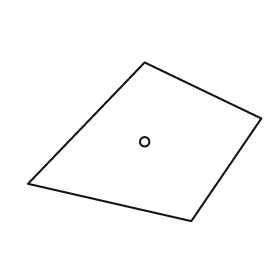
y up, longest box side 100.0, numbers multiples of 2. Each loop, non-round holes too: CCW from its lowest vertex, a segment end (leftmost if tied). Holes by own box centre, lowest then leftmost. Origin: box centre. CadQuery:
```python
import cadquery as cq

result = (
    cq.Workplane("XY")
    .moveTo(20.0, -34.0)
    .lineTo(50.0, 10.0)
    .lineTo(0.0, 34.0)
    .lineTo(-50.0, -18.0)
    .close()
    .moveTo(0.0, 0.0)
    .circle(2.0)
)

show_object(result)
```